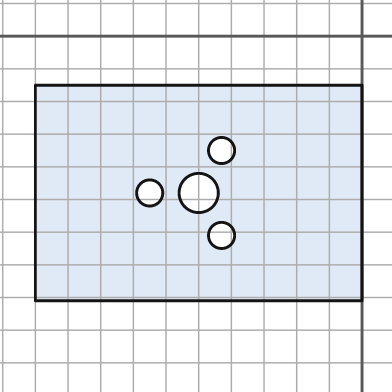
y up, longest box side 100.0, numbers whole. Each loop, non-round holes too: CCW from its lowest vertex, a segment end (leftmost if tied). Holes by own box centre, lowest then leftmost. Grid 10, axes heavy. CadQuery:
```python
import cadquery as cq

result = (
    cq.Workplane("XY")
    .moveTo(-100.0, -81.0)
    .lineTo(0.0, -81.0)
    .lineTo(0.0, -15.0)
    .lineTo(-100.0, -15.0)
    .close()
    .moveTo(-43.0, -61.0)
    .circle(4.0)
    .moveTo(-65.0, -48.0)
    .circle(4.0)
    .moveTo(-50.0, -48.0)
    .circle(6.0)
    .moveTo(-43.0, -35.0)
    .circle(4.0)
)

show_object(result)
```